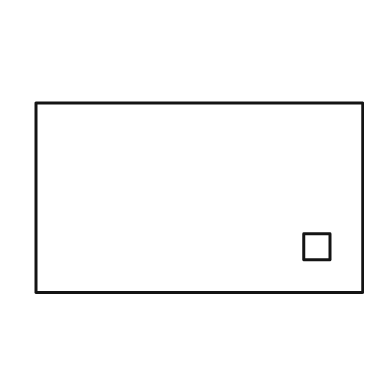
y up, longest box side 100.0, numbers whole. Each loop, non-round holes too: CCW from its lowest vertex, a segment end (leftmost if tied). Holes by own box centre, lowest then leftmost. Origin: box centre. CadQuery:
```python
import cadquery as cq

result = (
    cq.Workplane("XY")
    .moveTo(-50.0, -29.0)
    .lineTo(50.0, -29.0)
    .lineTo(50.0, 29.0)
    .lineTo(-50.0, 29.0)
    .close()
    .moveTo(32.0, -19.0)
    .lineTo(40.0, -19.0)
    .lineTo(40.0, -11.0)
    .lineTo(32.0, -11.0)
    .close()
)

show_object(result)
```